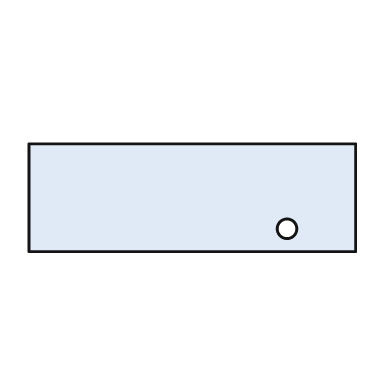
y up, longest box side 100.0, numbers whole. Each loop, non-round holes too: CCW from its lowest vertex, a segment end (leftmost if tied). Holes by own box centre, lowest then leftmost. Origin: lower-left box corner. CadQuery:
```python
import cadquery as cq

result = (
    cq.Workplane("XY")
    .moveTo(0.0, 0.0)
    .lineTo(100.0, 0.0)
    .lineTo(100.0, 33.0)
    .lineTo(0.0, 33.0)
    .close()
    .moveTo(79.0, 7.0)
    .circle(3.0)
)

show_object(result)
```